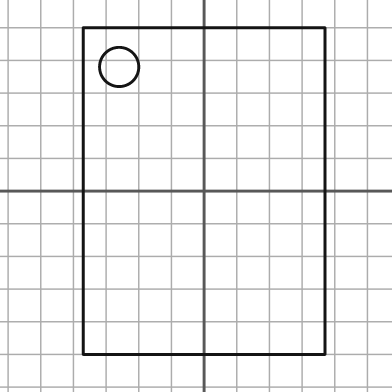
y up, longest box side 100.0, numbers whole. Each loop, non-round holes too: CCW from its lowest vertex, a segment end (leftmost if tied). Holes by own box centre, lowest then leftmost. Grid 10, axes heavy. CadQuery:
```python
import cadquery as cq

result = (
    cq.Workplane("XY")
    .moveTo(-37.0, -50.0)
    .lineTo(37.0, -50.0)
    .lineTo(37.0, 50.0)
    .lineTo(-37.0, 50.0)
    .close()
    .moveTo(-26.0, 38.0)
    .circle(6.0)
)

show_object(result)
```